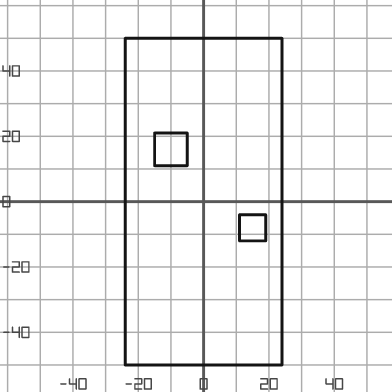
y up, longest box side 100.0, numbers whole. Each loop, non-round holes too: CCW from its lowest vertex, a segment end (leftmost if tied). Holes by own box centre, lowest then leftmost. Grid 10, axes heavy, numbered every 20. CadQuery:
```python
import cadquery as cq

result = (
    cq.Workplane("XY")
    .moveTo(-24.0, -50.0)
    .lineTo(24.0, -50.0)
    .lineTo(24.0, 50.0)
    .lineTo(-24.0, 50.0)
    .close()
    .moveTo(11.0, -12.0)
    .lineTo(19.0, -12.0)
    .lineTo(19.0, -4.0)
    .lineTo(11.0, -4.0)
    .close()
    .moveTo(-15.0, 11.0)
    .lineTo(-5.0, 11.0)
    .lineTo(-5.0, 21.0)
    .lineTo(-15.0, 21.0)
    .close()
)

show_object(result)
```